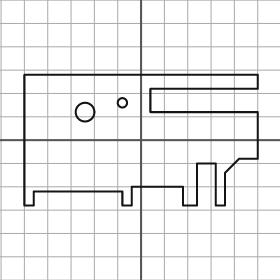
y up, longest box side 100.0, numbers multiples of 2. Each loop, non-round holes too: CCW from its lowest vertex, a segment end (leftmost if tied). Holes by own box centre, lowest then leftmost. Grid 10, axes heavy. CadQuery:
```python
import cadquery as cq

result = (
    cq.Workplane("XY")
    .moveTo(-50.0, -28.0)
    .lineTo(-46.0, -28.0)
    .lineTo(-46.0, -22.0)
    .lineTo(-8.0, -22.0)
    .lineTo(-8.0, -28.0)
    .lineTo(-4.0, -28.0)
    .lineTo(-4.0, -20.0)
    .lineTo(18.0, -20.0)
    .lineTo(18.0, -28.0)
    .lineTo(24.0, -28.0)
    .lineTo(24.0, -10.0)
    .lineTo(32.0, -10.0)
    .lineTo(32.0, -28.0)
    .lineTo(36.0, -28.0)
    .lineTo(36.0, -14.0)
    .lineTo(42.0, -8.0)
    .lineTo(50.0, -8.0)
    .lineTo(50.0, 12.0)
    .lineTo(4.0, 12.0)
    .lineTo(4.0, 22.0)
    .lineTo(50.0, 22.0)
    .lineTo(50.0, 28.0)
    .lineTo(-50.0, 28.0)
    .close()
    .moveTo(-24.0, 12.0)
    .circle(4.0)
    .moveTo(-8.0, 16.0)
    .circle(2.0)
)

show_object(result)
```